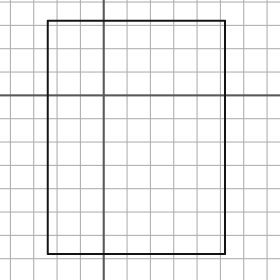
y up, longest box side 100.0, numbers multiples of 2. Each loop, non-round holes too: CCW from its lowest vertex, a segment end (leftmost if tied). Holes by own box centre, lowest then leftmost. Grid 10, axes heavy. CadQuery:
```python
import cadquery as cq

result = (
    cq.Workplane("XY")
    .moveTo(-24.0, -68.0)
    .lineTo(52.0, -68.0)
    .lineTo(52.0, 32.0)
    .lineTo(-24.0, 32.0)
    .close()
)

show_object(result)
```